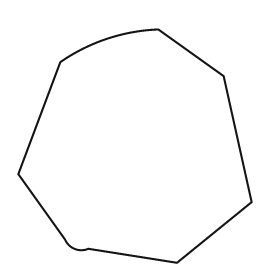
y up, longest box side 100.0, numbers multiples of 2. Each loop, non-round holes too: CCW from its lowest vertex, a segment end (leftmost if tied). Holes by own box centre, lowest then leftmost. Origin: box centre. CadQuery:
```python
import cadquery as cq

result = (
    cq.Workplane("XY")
    .moveTo(18.0, -50.0)
    .lineTo(50.0, -24.0)
    .lineTo(38.0, 30.0)
    .lineTo(10.0, 50.0)
    .threePointArc((-12.0, 46.0), (-32.0, 36.0))
    .lineTo(-50.0, -12.0)
    .lineTo(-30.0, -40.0)
    .threePointArc((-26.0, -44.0), (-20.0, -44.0))
    .close()
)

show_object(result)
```